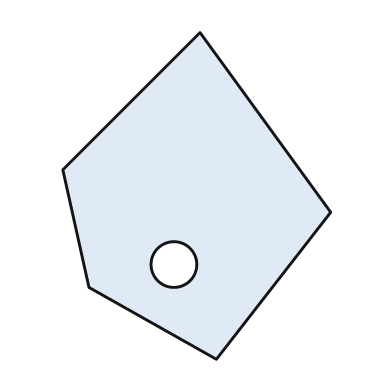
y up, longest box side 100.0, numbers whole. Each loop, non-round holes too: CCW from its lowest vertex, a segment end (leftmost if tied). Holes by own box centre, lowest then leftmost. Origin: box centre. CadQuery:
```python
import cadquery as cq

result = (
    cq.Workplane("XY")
    .moveTo(6.0, -50.0)
    .lineTo(41.0, -5.0)
    .lineTo(1.0, 50.0)
    .lineTo(-41.0, 8.0)
    .lineTo(-33.0, -28.0)
    .close()
    .moveTo(-7.0, -21.0)
    .circle(7.0)
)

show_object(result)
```